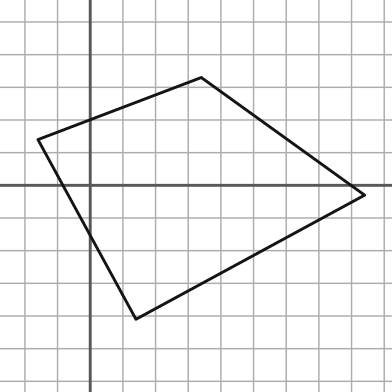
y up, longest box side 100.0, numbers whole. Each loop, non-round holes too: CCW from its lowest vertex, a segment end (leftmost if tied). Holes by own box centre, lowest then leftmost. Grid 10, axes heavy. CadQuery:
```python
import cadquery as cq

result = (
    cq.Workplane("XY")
    .moveTo(14.0, -41.0)
    .lineTo(84.0, -3.0)
    .lineTo(34.0, 33.0)
    .lineTo(-16.0, 14.0)
    .close()
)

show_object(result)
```